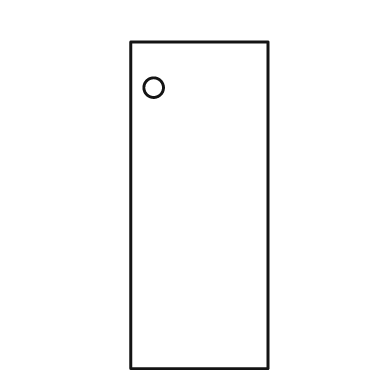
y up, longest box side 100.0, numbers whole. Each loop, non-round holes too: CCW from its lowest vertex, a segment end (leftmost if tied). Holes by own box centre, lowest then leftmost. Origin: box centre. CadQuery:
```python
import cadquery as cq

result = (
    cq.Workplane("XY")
    .moveTo(-21.0, -50.0)
    .lineTo(21.0, -50.0)
    .lineTo(21.0, 50.0)
    .lineTo(-21.0, 50.0)
    .close()
    .moveTo(-14.0, 36.0)
    .circle(3.0)
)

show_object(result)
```